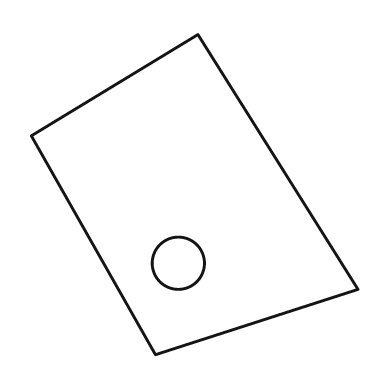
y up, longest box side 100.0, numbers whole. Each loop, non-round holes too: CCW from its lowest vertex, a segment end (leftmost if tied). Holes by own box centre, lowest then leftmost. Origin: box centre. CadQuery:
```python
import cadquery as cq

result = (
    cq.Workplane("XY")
    .moveTo(-12.0, -49.0)
    .lineTo(50.0, -29.0)
    .lineTo(1.0, 49.0)
    .lineTo(-50.0, 18.0)
    .close()
    .moveTo(-5.0, -21.0)
    .circle(8.0)
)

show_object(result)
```